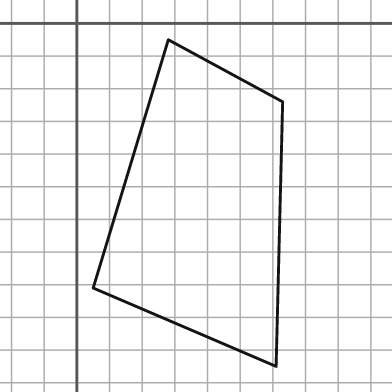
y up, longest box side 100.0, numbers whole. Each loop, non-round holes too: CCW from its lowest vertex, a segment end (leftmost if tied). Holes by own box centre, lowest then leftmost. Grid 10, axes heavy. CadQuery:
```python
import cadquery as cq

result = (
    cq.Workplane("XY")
    .moveTo(61.0, -105.0)
    .lineTo(63.0, -24.0)
    .lineTo(28.0, -5.0)
    .lineTo(5.0, -81.0)
    .close()
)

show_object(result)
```